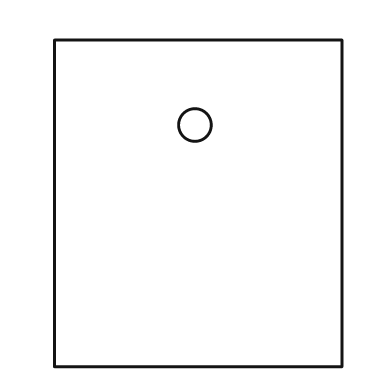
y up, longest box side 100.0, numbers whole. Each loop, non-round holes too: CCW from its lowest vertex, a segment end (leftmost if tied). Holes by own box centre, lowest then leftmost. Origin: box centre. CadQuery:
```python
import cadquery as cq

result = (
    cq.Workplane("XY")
    .moveTo(-44.0, -50.0)
    .lineTo(44.0, -50.0)
    .lineTo(44.0, 50.0)
    .lineTo(-44.0, 50.0)
    .close()
    .moveTo(-1.0, 24.0)
    .circle(5.0)
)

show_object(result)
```